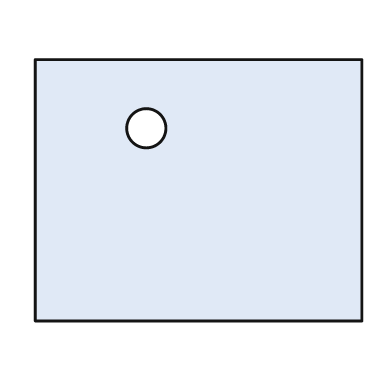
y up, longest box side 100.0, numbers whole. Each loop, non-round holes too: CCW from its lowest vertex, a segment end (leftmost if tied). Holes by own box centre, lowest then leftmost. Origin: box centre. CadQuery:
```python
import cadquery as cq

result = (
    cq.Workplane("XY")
    .moveTo(-50.0, -40.0)
    .lineTo(50.0, -40.0)
    .lineTo(50.0, 40.0)
    .lineTo(-50.0, 40.0)
    .close()
    .moveTo(-16.0, 19.0)
    .circle(6.0)
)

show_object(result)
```